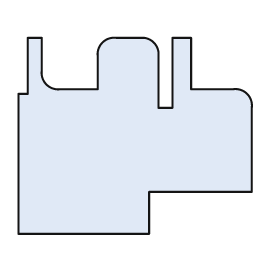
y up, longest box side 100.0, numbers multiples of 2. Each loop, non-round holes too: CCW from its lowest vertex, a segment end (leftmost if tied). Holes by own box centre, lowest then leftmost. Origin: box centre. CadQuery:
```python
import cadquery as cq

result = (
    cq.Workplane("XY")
    .moveTo(-50.0, -42.0)
    .lineTo(6.0, -42.0)
    .lineTo(6.0, -24.0)
    .lineTo(50.0, -24.0)
    .lineTo(50.0, 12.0)
    .threePointArc((48.0, 18.0), (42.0, 20.0))
    .lineTo(24.0, 20.0)
    .lineTo(24.0, 42.0)
    .lineTo(16.0, 42.0)
    .lineTo(16.0, 12.0)
    .lineTo(10.0, 12.0)
    .lineTo(10.0, 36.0)
    .threePointArc((8.0, 40.0), (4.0, 42.0))
    .lineTo(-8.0, 42.0)
    .threePointArc((-14.0, 40.0), (-16.0, 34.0))
    .lineTo(-16.0, 20.0)
    .lineTo(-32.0, 20.0)
    .threePointArc((-38.0, 22.0), (-40.0, 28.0))
    .lineTo(-40.0, 42.0)
    .lineTo(-46.0, 42.0)
    .lineTo(-46.0, 18.0)
    .lineTo(-50.0, 18.0)
    .close()
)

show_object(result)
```